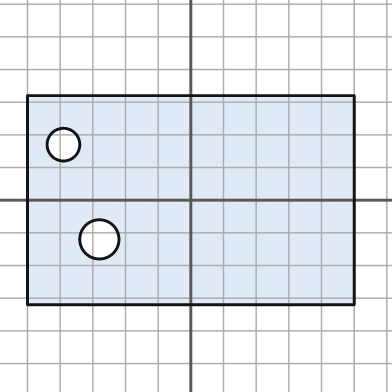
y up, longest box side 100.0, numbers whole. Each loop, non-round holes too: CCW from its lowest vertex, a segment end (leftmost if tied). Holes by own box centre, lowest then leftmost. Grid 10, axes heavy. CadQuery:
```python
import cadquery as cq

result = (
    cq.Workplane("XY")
    .moveTo(-50.0, -32.0)
    .lineTo(50.0, -32.0)
    .lineTo(50.0, 32.0)
    .lineTo(-50.0, 32.0)
    .close()
    .moveTo(-28.0, -12.0)
    .circle(6.0)
    .moveTo(-39.0, 17.0)
    .circle(5.0)
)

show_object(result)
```